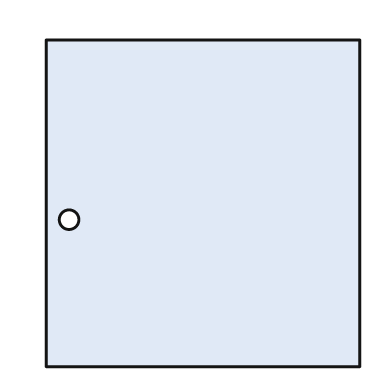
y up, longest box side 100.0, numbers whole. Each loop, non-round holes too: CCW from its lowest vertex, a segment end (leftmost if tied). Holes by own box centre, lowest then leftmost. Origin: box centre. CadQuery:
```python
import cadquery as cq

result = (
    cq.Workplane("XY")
    .moveTo(-48.0, -50.0)
    .lineTo(48.0, -50.0)
    .lineTo(48.0, 50.0)
    .lineTo(-48.0, 50.0)
    .close()
    .moveTo(-41.0, -5.0)
    .circle(3.0)
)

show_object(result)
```